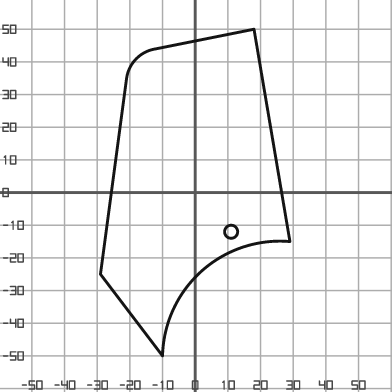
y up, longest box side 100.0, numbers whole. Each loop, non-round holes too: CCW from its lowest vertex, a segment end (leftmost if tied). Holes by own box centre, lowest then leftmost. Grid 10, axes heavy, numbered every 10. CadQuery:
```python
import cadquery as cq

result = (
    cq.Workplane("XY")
    .moveTo(-10.0, -50.0)
    .threePointArc((2.0, -24.0), (29.0, -15.0))
    .lineTo(18.0, 50.0)
    .lineTo(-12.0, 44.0)
    .threePointArc((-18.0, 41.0), (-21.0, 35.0))
    .lineTo(-29.0, -25.0)
    .close()
    .moveTo(11.0, -12.0)
    .circle(2.0)
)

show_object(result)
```